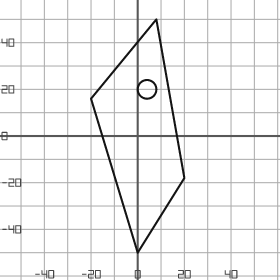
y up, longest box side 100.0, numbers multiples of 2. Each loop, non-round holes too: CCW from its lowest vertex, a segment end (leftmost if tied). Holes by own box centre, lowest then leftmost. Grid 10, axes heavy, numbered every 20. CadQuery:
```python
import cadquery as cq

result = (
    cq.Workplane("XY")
    .moveTo(0.0, -50.0)
    .lineTo(20.0, -18.0)
    .lineTo(8.0, 50.0)
    .lineTo(-20.0, 16.0)
    .close()
    .moveTo(4.0, 20.0)
    .circle(4.0)
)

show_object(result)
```